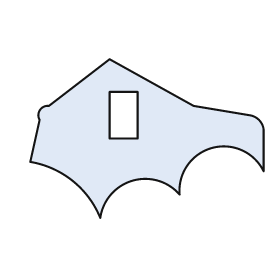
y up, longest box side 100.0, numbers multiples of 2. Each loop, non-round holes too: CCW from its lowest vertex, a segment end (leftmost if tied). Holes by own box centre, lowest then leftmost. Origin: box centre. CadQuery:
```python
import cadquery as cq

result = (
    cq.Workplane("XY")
    .moveTo(-20.0, -34.0)
    .threePointArc((-6.0, -18.0), (14.0, -24.0))
    .threePointArc((28.0, -4.0), (50.0, -14.0))
    .lineTo(50.0, 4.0)
    .threePointArc((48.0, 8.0), (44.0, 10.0))
    .lineTo(20.0, 14.0)
    .lineTo(-16.0, 34.0)
    .lineTo(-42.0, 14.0)
    .threePointArc((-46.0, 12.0), (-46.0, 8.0))
    .lineTo(-50.0, -10.0)
    .threePointArc((-32.0, -18.0), (-20.0, -34.0))
    .close()
    .moveTo(-16.0, 0.0)
    .lineTo(-4.0, 0.0)
    .lineTo(-4.0, 20.0)
    .lineTo(-16.0, 20.0)
    .close()
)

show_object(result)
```